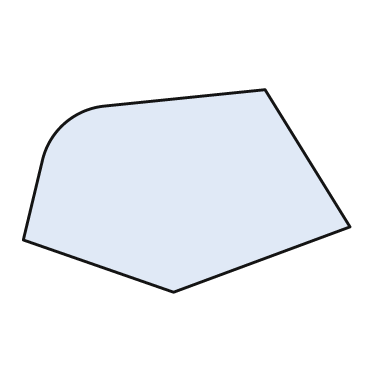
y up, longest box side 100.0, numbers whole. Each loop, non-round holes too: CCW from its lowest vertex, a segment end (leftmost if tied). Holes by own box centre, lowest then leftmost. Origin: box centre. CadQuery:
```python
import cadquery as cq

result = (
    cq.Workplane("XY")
    .moveTo(-4.0, -31.0)
    .lineTo(50.0, -11.0)
    .lineTo(24.0, 31.0)
    .lineTo(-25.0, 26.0)
    .threePointArc((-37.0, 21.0), (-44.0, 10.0))
    .lineTo(-50.0, -15.0)
    .close()
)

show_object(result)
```